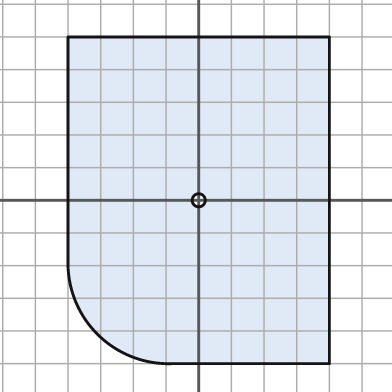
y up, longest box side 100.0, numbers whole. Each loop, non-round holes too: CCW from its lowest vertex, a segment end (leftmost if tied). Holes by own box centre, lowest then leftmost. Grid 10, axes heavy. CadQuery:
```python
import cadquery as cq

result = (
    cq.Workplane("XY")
    .moveTo(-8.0, -50.0)
    .lineTo(40.0, -50.0)
    .lineTo(40.0, 50.0)
    .lineTo(-40.0, 50.0)
    .lineTo(-40.0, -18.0)
    .threePointArc((-31.0, -41.0), (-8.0, -50.0))
    .close()
    .moveTo(0.0, 0.0)
    .circle(2.0)
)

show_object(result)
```